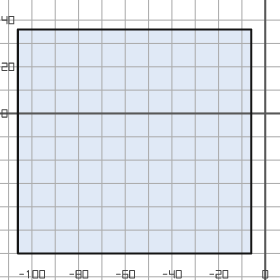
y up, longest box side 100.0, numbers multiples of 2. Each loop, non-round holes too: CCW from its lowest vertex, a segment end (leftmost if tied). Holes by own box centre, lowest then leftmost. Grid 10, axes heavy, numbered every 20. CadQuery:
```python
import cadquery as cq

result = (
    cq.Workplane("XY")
    .moveTo(-106.0, -60.0)
    .lineTo(-6.0, -60.0)
    .lineTo(-6.0, 36.0)
    .lineTo(-106.0, 36.0)
    .close()
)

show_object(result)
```